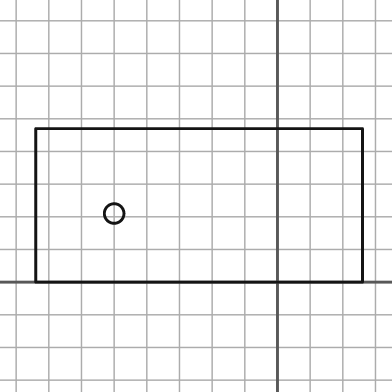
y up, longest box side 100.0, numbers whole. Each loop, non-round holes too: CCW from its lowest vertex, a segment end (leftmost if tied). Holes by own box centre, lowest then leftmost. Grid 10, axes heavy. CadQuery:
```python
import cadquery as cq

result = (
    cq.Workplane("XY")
    .moveTo(-74.0, 0.0)
    .lineTo(26.0, 0.0)
    .lineTo(26.0, 47.0)
    .lineTo(-74.0, 47.0)
    .close()
    .moveTo(-50.0, 21.0)
    .circle(3.0)
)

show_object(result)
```